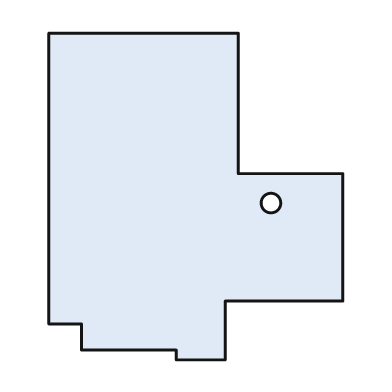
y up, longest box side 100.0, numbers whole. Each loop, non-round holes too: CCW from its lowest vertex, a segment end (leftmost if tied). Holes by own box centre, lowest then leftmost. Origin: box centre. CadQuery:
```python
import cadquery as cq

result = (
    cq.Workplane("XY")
    .moveTo(-6.0, -50.0)
    .lineTo(9.0, -50.0)
    .lineTo(9.0, -32.0)
    .lineTo(45.0, -32.0)
    .lineTo(45.0, 7.0)
    .lineTo(13.0, 7.0)
    .lineTo(13.0, 50.0)
    .lineTo(-45.0, 50.0)
    .lineTo(-45.0, -39.0)
    .lineTo(-35.0, -39.0)
    .lineTo(-35.0, -47.0)
    .lineTo(-6.0, -47.0)
    .close()
    .moveTo(23.0, -2.0)
    .circle(3.0)
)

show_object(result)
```